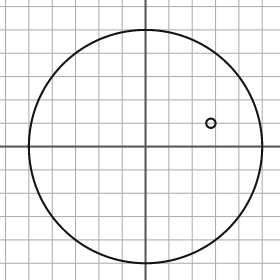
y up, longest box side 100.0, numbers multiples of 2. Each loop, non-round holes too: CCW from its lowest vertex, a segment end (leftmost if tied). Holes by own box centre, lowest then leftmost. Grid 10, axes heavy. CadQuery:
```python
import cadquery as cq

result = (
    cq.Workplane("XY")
    .moveTo(0.0, 0.0)
    .circle(50.0)
    .moveTo(28.0, 10.0)
    .circle(2.0)
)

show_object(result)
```